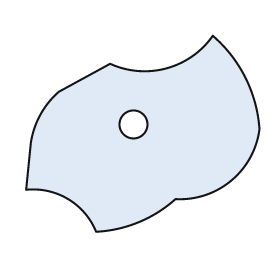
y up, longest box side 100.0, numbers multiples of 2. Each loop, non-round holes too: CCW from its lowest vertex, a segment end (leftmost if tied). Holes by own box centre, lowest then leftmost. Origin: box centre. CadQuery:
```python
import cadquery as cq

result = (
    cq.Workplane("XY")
    .moveTo(-20.0, -42.0)
    .threePointArc((-2.0, -38.0), (14.0, -28.0))
    .threePointArc((38.0, -20.0), (50.0, 2.0))
    .threePointArc((44.0, 24.0), (30.0, 42.0))
    .threePointArc((10.0, 28.0), (-14.0, 30.0))
    .lineTo(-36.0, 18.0)
    .threePointArc((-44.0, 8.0), (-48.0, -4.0))
    .lineTo(-50.0, -24.0)
    .threePointArc((-32.0, -28.0), (-20.0, -42.0))
    .close()
    .moveTo(-4.0, 4.0)
    .circle(6.0)
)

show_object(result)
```